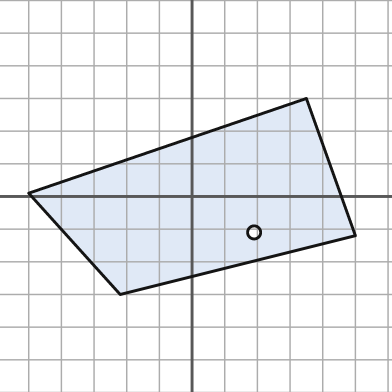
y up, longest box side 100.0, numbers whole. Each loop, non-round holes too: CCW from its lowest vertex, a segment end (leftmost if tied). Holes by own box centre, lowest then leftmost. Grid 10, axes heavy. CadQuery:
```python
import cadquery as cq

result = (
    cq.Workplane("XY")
    .moveTo(-22.0, -30.0)
    .lineTo(50.0, -12.0)
    .lineTo(35.0, 30.0)
    .lineTo(-50.0, 1.0)
    .close()
    .moveTo(19.0, -11.0)
    .circle(2.0)
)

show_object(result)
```